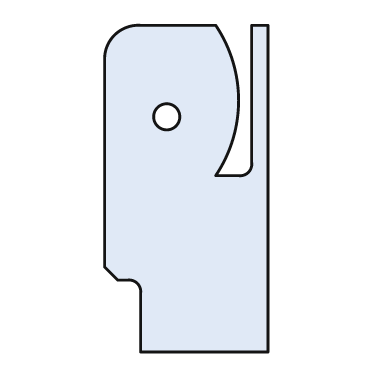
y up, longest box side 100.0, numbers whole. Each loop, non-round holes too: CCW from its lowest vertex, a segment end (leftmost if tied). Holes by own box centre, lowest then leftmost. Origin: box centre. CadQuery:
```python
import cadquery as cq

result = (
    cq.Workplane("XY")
    .moveTo(-14.0, -50.0)
    .lineTo(25.0, -50.0)
    .lineTo(25.0, 50.0)
    .lineTo(20.0, 50.0)
    .lineTo(20.0, 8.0)
    .threePointArc((19.0, 5.0), (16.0, 4.0))
    .lineTo(9.0, 4.0)
    .threePointArc((16.0, 27.0), (9.0, 50.0))
    .lineTo(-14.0, 50.0)
    .threePointArc((-22.0, 47.0), (-25.0, 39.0))
    .lineTo(-25.0, -24.0)
    .lineTo(-21.0, -28.0)
    .lineTo(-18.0, -28.0)
    .threePointArc((-15.0, -29.0), (-14.0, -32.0))
    .close()
    .moveTo(-6.0, 22.0)
    .circle(4.0)
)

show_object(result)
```